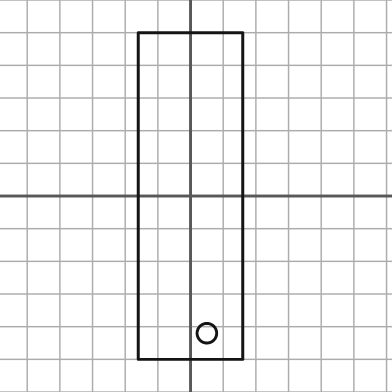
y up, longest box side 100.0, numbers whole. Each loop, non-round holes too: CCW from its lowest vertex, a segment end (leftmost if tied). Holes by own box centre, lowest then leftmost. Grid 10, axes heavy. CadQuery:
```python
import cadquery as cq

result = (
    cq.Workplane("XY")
    .moveTo(-16.0, -50.0)
    .lineTo(16.0, -50.0)
    .lineTo(16.0, 50.0)
    .lineTo(-16.0, 50.0)
    .close()
    .moveTo(5.0, -42.0)
    .circle(3.0)
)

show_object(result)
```